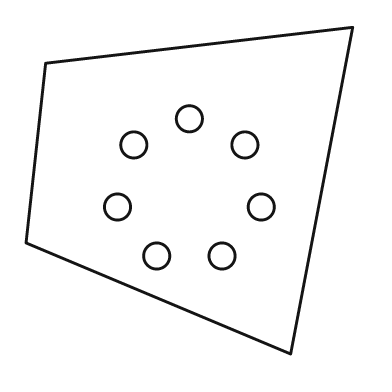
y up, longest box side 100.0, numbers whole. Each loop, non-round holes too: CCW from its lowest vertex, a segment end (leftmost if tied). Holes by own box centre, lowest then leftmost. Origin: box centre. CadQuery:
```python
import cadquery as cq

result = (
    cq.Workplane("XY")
    .moveTo(31.0, -50.0)
    .lineTo(50.0, 50.0)
    .lineTo(-44.0, 39.0)
    .lineTo(-50.0, -16.0)
    .close()
    .moveTo(-10.0, -20.0)
    .circle(4.0)
    .moveTo(10.0, -20.0)
    .circle(4.0)
    .moveTo(-22.0, -5.0)
    .circle(4.0)
    .moveTo(22.0, -5.0)
    .circle(4.0)
    .moveTo(-17.0, 14.0)
    .circle(4.0)
    .moveTo(17.0, 14.0)
    .circle(4.0)
    .moveTo(0.0, 22.0)
    .circle(4.0)
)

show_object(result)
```